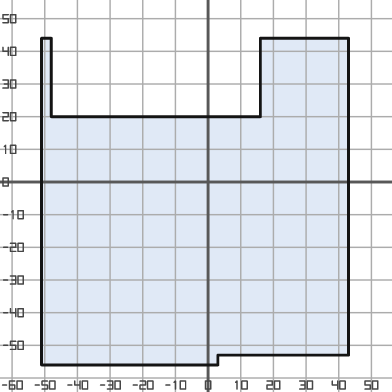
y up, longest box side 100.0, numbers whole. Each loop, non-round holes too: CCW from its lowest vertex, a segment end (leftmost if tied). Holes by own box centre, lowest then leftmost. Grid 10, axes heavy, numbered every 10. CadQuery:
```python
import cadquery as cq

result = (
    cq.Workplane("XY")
    .moveTo(-51.0, -56.0)
    .lineTo(3.0, -56.0)
    .lineTo(3.0, -53.0)
    .lineTo(43.0, -53.0)
    .lineTo(43.0, 44.0)
    .lineTo(16.0, 44.0)
    .lineTo(16.0, 20.0)
    .lineTo(-48.0, 20.0)
    .lineTo(-48.0, 44.0)
    .lineTo(-51.0, 44.0)
    .close()
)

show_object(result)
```